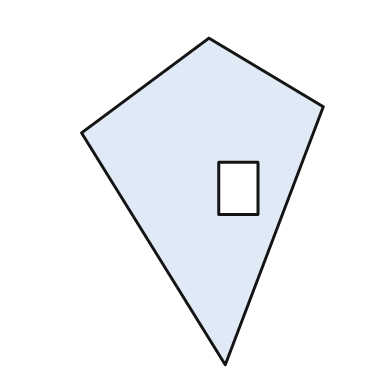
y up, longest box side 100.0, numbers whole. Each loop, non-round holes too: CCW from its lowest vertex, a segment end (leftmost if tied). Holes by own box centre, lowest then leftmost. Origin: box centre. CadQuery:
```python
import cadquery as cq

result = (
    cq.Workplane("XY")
    .moveTo(7.0, -50.0)
    .lineTo(37.0, 29.0)
    .lineTo(2.0, 50.0)
    .lineTo(-37.0, 21.0)
    .close()
    .moveTo(5.0, -4.0)
    .lineTo(17.0, -4.0)
    .lineTo(17.0, 12.0)
    .lineTo(5.0, 12.0)
    .close()
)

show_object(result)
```